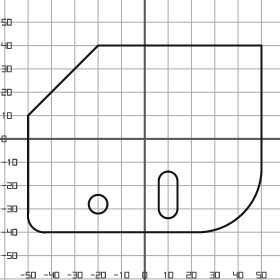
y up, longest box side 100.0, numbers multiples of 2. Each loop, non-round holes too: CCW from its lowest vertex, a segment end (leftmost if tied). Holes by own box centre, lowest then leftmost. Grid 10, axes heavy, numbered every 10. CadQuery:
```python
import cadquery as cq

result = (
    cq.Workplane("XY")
    .moveTo(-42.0, -40.0)
    .lineTo(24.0, -40.0)
    .threePointArc((42.0, -32.0), (50.0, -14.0))
    .lineTo(50.0, 40.0)
    .lineTo(-20.0, 40.0)
    .lineTo(-50.0, 10.0)
    .lineTo(-50.0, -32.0)
    .threePointArc((-48.0, -38.0), (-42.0, -40.0))
    .close()
    .moveTo(-20.0, -28.0)
    .circle(4.0)
    .moveTo(6.0, -30.0)
    .threePointArc((10.0, -34.0), (14.0, -30.0))
    .lineTo(14.0, -18.0)
    .threePointArc((10.0, -14.0), (6.0, -18.0))
    .close()
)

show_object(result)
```